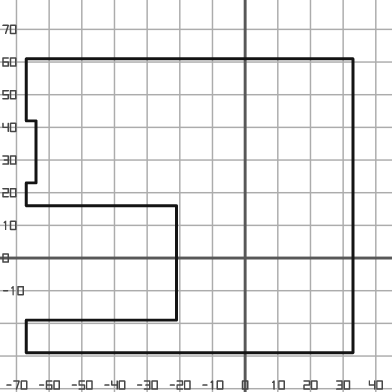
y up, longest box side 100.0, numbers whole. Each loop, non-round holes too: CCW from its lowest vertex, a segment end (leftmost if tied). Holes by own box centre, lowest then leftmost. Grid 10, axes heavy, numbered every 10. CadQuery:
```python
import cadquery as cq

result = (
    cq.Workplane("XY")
    .moveTo(-67.0, -29.0)
    .lineTo(33.0, -29.0)
    .lineTo(33.0, 61.0)
    .lineTo(-67.0, 61.0)
    .lineTo(-67.0, 42.0)
    .lineTo(-64.0, 42.0)
    .lineTo(-64.0, 23.0)
    .lineTo(-67.0, 23.0)
    .lineTo(-67.0, 16.0)
    .lineTo(-21.0, 16.0)
    .lineTo(-21.0, -19.0)
    .lineTo(-67.0, -19.0)
    .close()
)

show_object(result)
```